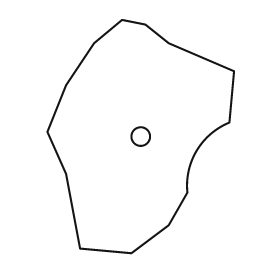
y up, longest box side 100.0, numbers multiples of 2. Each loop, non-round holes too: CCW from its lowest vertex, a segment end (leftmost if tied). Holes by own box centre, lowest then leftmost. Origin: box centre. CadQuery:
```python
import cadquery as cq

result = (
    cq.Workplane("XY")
    .moveTo(-4.0, -50.0)
    .lineTo(12.0, -38.0)
    .lineTo(20.0, -24.0)
    .threePointArc((24.0, -6.0), (38.0, 6.0))
    .lineTo(40.0, 28.0)
    .lineTo(12.0, 40.0)
    .lineTo(2.0, 48.0)
    .lineTo(-8.0, 50.0)
    .lineTo(-20.0, 40.0)
    .lineTo(-32.0, 22.0)
    .lineTo(-40.0, 2.0)
    .lineTo(-32.0, -16.0)
    .lineTo(-26.0, -48.0)
    .close()
    .moveTo(0.0, 0.0)
    .circle(4.0)
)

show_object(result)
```